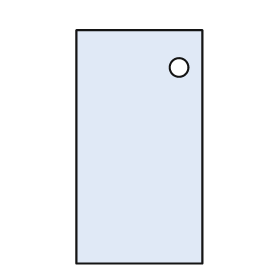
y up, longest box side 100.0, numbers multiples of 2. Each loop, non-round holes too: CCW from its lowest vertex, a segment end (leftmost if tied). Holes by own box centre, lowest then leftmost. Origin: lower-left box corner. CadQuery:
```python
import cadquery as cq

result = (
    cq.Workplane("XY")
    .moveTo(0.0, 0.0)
    .lineTo(54.0, 0.0)
    .lineTo(54.0, 100.0)
    .lineTo(0.0, 100.0)
    .close()
    .moveTo(44.0, 84.0)
    .circle(4.0)
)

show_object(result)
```